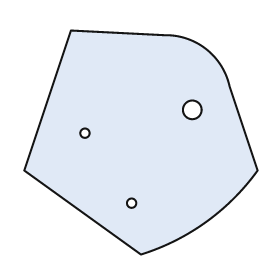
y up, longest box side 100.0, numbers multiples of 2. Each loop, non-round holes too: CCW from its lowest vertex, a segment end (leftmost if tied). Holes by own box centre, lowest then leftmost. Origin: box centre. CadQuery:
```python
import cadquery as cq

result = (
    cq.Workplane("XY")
    .moveTo(0.0, -48.0)
    .threePointArc((28.0, -34.0), (50.0, -12.0))
    .lineTo(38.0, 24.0)
    .threePointArc((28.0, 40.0), (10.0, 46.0))
    .lineTo(-30.0, 48.0)
    .lineTo(-50.0, -12.0)
    .close()
    .moveTo(-4.0, -26.0)
    .circle(2.0)
    .moveTo(-24.0, 4.0)
    .circle(2.0)
    .moveTo(22.0, 14.0)
    .circle(4.0)
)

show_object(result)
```